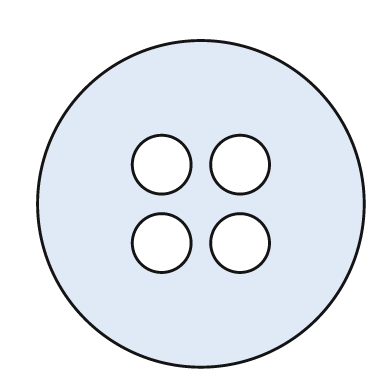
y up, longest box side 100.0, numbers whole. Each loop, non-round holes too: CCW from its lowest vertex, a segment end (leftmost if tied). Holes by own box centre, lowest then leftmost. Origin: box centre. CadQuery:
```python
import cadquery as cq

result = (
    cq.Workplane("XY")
    .moveTo(0.0, 0.0)
    .circle(50.0)
    .moveTo(-12.0, -12.0)
    .circle(9.0)
    .moveTo(12.0, -12.0)
    .circle(9.0)
    .moveTo(-12.0, 12.0)
    .circle(9.0)
    .moveTo(12.0, 12.0)
    .circle(9.0)
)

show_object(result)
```